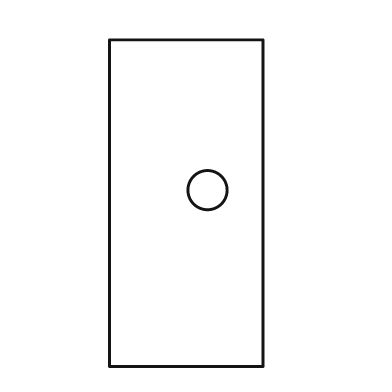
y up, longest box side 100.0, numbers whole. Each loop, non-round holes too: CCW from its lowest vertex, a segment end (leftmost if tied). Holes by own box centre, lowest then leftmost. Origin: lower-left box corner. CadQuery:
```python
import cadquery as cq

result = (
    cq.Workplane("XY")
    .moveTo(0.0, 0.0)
    .lineTo(47.0, 0.0)
    .lineTo(47.0, 100.0)
    .lineTo(0.0, 100.0)
    .close()
    .moveTo(30.0, 54.0)
    .circle(6.0)
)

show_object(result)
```